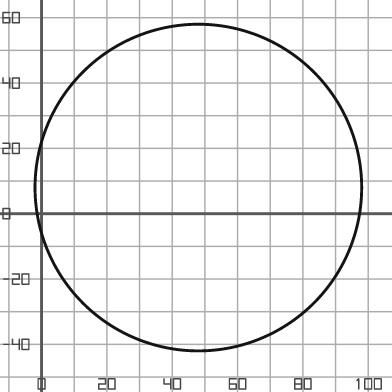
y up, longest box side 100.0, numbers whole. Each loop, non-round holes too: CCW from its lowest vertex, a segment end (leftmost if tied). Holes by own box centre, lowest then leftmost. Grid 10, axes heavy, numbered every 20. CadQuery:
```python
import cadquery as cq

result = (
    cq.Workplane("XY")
    .moveTo(48.0, 8.0)
    .circle(50.0)
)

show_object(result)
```